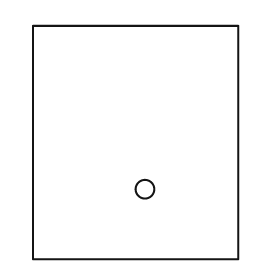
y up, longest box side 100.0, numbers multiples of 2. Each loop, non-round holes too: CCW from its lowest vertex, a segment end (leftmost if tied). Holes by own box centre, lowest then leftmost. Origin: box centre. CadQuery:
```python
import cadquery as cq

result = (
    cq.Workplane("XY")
    .moveTo(-44.0, -50.0)
    .lineTo(44.0, -50.0)
    .lineTo(44.0, 50.0)
    .lineTo(-44.0, 50.0)
    .close()
    .moveTo(4.0, -20.0)
    .circle(4.0)
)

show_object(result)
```